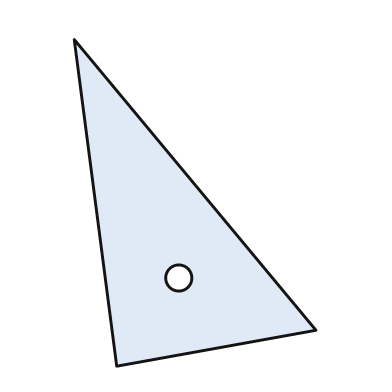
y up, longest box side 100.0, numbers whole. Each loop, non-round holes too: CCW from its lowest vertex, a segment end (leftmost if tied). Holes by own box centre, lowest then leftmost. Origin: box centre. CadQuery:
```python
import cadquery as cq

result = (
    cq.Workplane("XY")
    .moveTo(-24.0, -50.0)
    .lineTo(37.0, -39.0)
    .lineTo(-37.0, 50.0)
    .close()
    .moveTo(-5.0, -23.0)
    .circle(4.0)
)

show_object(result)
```